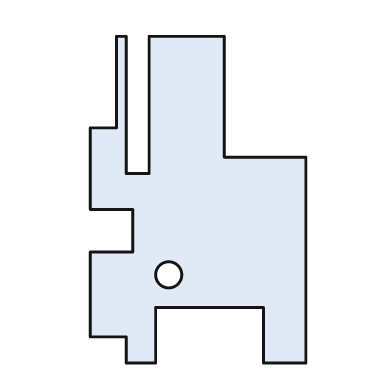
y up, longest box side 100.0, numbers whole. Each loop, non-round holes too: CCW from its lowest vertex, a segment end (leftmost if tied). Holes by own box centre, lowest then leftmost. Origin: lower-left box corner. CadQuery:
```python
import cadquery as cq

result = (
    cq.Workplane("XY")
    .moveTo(11.0, 0.0)
    .lineTo(20.0, 0.0)
    .lineTo(20.0, 17.0)
    .lineTo(53.0, 17.0)
    .lineTo(53.0, 0.0)
    .lineTo(66.0, 0.0)
    .lineTo(66.0, 63.0)
    .lineTo(41.0, 63.0)
    .lineTo(41.0, 100.0)
    .lineTo(18.0, 100.0)
    .lineTo(18.0, 58.0)
    .lineTo(11.0, 58.0)
    .lineTo(11.0, 100.0)
    .lineTo(8.0, 100.0)
    .lineTo(8.0, 72.0)
    .lineTo(0.0, 72.0)
    .lineTo(0.0, 47.0)
    .lineTo(13.0, 47.0)
    .lineTo(13.0, 34.0)
    .lineTo(0.0, 34.0)
    .lineTo(0.0, 8.0)
    .lineTo(11.0, 8.0)
    .close()
    .moveTo(24.0, 27.0)
    .circle(4.0)
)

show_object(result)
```